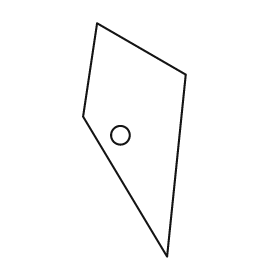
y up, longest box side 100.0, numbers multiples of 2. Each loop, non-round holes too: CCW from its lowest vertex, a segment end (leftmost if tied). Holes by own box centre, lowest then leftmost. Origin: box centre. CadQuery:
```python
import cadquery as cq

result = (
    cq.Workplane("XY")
    .moveTo(14.0, -50.0)
    .lineTo(22.0, 28.0)
    .lineTo(-16.0, 50.0)
    .lineTo(-22.0, 10.0)
    .close()
    .moveTo(-6.0, 2.0)
    .circle(4.0)
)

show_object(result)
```